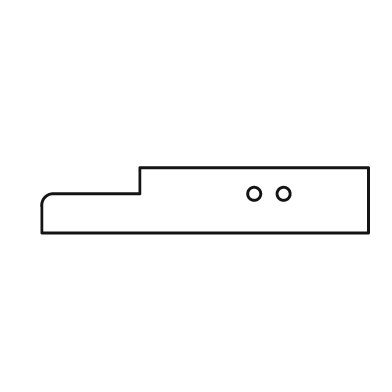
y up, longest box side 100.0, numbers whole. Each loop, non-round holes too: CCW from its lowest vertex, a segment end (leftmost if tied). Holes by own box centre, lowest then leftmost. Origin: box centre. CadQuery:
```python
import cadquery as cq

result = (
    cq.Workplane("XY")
    .moveTo(-50.0, -10.0)
    .lineTo(50.0, -10.0)
    .lineTo(50.0, 10.0)
    .lineTo(-20.0, 10.0)
    .lineTo(-20.0, 2.0)
    .lineTo(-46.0, 2.0)
    .threePointArc((-49.0, 1.0), (-50.0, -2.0))
    .close()
    .moveTo(15.0, 2.0)
    .circle(2.0)
    .moveTo(24.0, 2.0)
    .circle(2.0)
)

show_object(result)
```